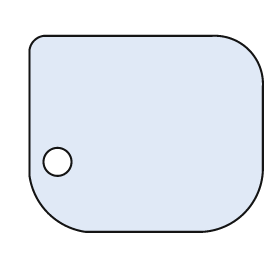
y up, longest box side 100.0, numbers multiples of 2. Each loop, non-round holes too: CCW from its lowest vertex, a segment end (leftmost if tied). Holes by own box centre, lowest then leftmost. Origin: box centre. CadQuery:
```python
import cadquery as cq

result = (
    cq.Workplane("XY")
    .moveTo(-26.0, -42.0)
    .lineTo(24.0, -42.0)
    .threePointArc((42.0, -34.0), (50.0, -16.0))
    .lineTo(50.0, 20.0)
    .threePointArc((44.0, 36.0), (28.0, 42.0))
    .lineTo(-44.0, 42.0)
    .threePointArc((-48.0, 40.0), (-50.0, 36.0))
    .lineTo(-50.0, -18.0)
    .threePointArc((-42.0, -34.0), (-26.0, -42.0))
    .close()
    .moveTo(-38.0, -12.0)
    .circle(6.0)
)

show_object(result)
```